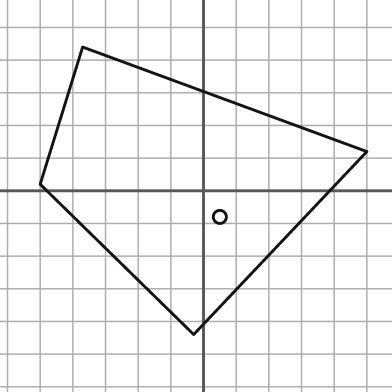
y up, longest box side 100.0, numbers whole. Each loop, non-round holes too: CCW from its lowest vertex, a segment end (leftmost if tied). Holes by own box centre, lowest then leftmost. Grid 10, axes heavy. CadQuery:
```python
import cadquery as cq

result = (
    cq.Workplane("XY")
    .moveTo(-3.0, -44.0)
    .lineTo(50.0, 12.0)
    .lineTo(-37.0, 44.0)
    .lineTo(-50.0, 2.0)
    .close()
    .moveTo(5.0, -8.0)
    .circle(2.0)
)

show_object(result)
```